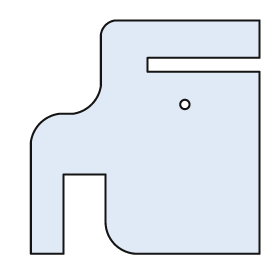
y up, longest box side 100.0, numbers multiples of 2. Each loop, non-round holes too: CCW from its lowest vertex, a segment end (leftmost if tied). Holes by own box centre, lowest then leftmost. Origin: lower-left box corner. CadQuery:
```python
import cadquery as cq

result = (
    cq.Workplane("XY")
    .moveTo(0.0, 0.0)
    .lineTo(14.0, 0.0)
    .lineTo(14.0, 34.0)
    .lineTo(32.0, 34.0)
    .lineTo(32.0, 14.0)
    .threePointArc((36.0, 4.0), (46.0, 0.0))
    .lineTo(98.0, 0.0)
    .lineTo(98.0, 78.0)
    .lineTo(50.0, 78.0)
    .lineTo(50.0, 84.0)
    .lineTo(98.0, 84.0)
    .lineTo(98.0, 100.0)
    .lineTo(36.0, 100.0)
    .threePointArc((32.0, 98.0), (30.0, 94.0))
    .lineTo(30.0, 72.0)
    .threePointArc((26.0, 64.0), (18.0, 60.0))
    .lineTo(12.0, 60.0)
    .threePointArc((4.0, 56.0), (0.0, 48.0))
    .close()
    .moveTo(66.0, 64.0)
    .circle(2.0)
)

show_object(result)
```